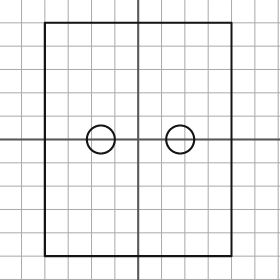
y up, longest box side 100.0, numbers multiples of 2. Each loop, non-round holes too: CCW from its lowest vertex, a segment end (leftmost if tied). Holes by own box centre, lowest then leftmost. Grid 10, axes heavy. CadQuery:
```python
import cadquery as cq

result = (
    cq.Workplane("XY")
    .moveTo(-40.0, -50.0)
    .lineTo(40.0, -50.0)
    .lineTo(40.0, 50.0)
    .lineTo(-40.0, 50.0)
    .close()
    .moveTo(-16.0, 0.0)
    .circle(6.0)
    .moveTo(18.0, 0.0)
    .circle(6.0)
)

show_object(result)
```